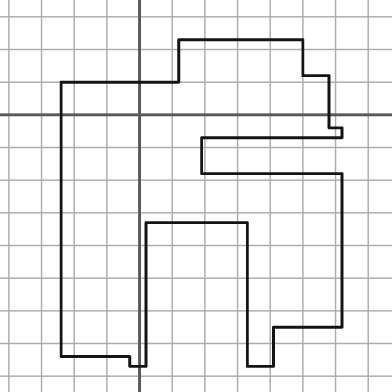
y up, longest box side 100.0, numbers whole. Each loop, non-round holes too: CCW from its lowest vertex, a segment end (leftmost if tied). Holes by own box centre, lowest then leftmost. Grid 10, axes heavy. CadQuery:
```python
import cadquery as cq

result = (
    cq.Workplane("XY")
    .moveTo(-3.0, -77.0)
    .lineTo(2.0, -77.0)
    .lineTo(2.0, -33.0)
    .lineTo(33.0, -33.0)
    .lineTo(33.0, -77.0)
    .lineTo(41.0, -77.0)
    .lineTo(41.0, -65.0)
    .lineTo(62.0, -65.0)
    .lineTo(62.0, -18.0)
    .lineTo(19.0, -18.0)
    .lineTo(19.0, -7.0)
    .lineTo(62.0, -7.0)
    .lineTo(62.0, -4.0)
    .lineTo(58.0, -4.0)
    .lineTo(58.0, 12.0)
    .lineTo(50.0, 12.0)
    .lineTo(50.0, 23.0)
    .lineTo(12.0, 23.0)
    .lineTo(12.0, 10.0)
    .lineTo(-24.0, 10.0)
    .lineTo(-24.0, -74.0)
    .lineTo(-3.0, -74.0)
    .close()
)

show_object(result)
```